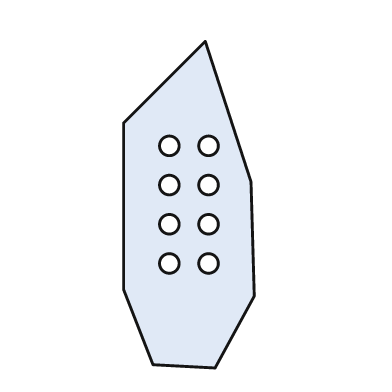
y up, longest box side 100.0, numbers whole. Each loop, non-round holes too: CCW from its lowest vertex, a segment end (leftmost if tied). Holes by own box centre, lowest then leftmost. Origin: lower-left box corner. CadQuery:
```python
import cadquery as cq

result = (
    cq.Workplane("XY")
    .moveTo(28.0, 0.0)
    .lineTo(40.0, 22.0)
    .lineTo(39.0, 57.0)
    .lineTo(25.0, 100.0)
    .lineTo(0.0, 75.0)
    .lineTo(0.0, 24.0)
    .lineTo(9.0, 1.0)
    .close()
    .moveTo(14.0, 32.0)
    .circle(3.0)
    .moveTo(26.0, 32.0)
    .circle(3.0)
    .moveTo(14.0, 44.0)
    .circle(3.0)
    .moveTo(26.0, 44.0)
    .circle(3.0)
    .moveTo(14.0, 56.0)
    .circle(3.0)
    .moveTo(26.0, 56.0)
    .circle(3.0)
    .moveTo(14.0, 68.0)
    .circle(3.0)
    .moveTo(26.0, 68.0)
    .circle(3.0)
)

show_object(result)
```